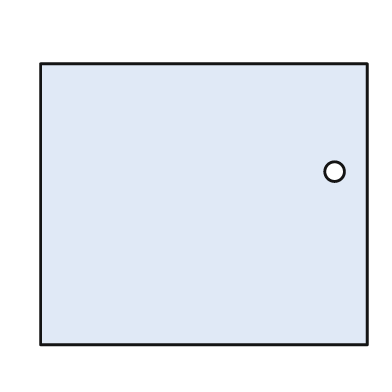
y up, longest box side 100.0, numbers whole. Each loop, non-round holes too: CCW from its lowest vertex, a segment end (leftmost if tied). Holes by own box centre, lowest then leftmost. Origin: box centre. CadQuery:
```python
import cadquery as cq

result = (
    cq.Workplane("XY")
    .moveTo(-50.0, -43.0)
    .lineTo(50.0, -43.0)
    .lineTo(50.0, 43.0)
    .lineTo(-50.0, 43.0)
    .close()
    .moveTo(40.0, 10.0)
    .circle(3.0)
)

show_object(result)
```